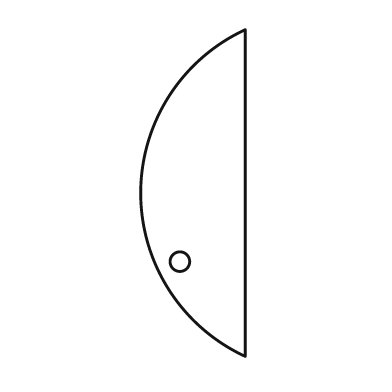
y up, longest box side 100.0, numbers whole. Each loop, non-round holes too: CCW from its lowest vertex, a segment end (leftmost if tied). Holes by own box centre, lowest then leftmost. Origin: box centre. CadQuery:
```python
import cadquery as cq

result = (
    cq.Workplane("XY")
    .moveTo(16.0, -50.0)
    .lineTo(16.0, 50.0)
    .threePointArc((-16.0, 0.0), (16.0, -50.0))
    .close()
    .moveTo(-4.0, -21.0)
    .circle(3.0)
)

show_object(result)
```